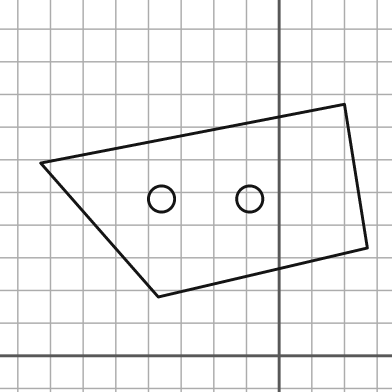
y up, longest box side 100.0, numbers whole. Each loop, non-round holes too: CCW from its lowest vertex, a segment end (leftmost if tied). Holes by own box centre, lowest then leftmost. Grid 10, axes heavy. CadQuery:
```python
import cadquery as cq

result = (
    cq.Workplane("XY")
    .moveTo(-37.0, 18.0)
    .lineTo(27.0, 33.0)
    .lineTo(20.0, 77.0)
    .lineTo(-73.0, 59.0)
    .close()
    .moveTo(-36.0, 48.0)
    .circle(4.0)
    .moveTo(-9.0, 48.0)
    .circle(4.0)
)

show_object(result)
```